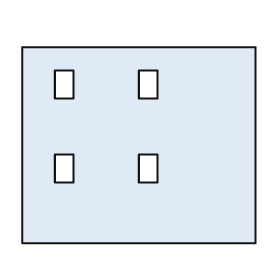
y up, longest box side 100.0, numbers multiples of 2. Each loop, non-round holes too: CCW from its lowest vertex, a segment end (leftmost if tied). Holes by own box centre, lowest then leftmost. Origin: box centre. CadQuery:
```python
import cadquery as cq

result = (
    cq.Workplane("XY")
    .moveTo(-50.0, -42.0)
    .lineTo(50.0, -42.0)
    .lineTo(50.0, 42.0)
    .lineTo(-50.0, 42.0)
    .close()
    .moveTo(-36.0, -16.0)
    .lineTo(-28.0, -16.0)
    .lineTo(-28.0, -4.0)
    .lineTo(-36.0, -4.0)
    .close()
    .moveTo(0.0, -16.0)
    .lineTo(8.0, -16.0)
    .lineTo(8.0, -4.0)
    .lineTo(0.0, -4.0)
    .close()
    .moveTo(-36.0, 20.0)
    .lineTo(-28.0, 20.0)
    .lineTo(-28.0, 32.0)
    .lineTo(-36.0, 32.0)
    .close()
    .moveTo(0.0, 20.0)
    .lineTo(8.0, 20.0)
    .lineTo(8.0, 32.0)
    .lineTo(0.0, 32.0)
    .close()
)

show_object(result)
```